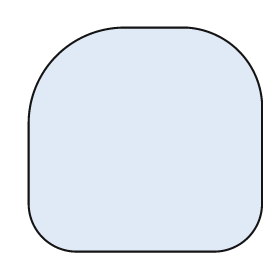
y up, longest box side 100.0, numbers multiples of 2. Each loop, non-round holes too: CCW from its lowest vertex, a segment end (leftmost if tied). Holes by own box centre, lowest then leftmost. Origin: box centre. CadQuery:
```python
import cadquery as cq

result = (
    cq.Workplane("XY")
    .moveTo(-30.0, -48.0)
    .lineTo(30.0, -48.0)
    .threePointArc((44.0, -42.0), (50.0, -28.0))
    .lineTo(50.0, 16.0)
    .threePointArc((40.0, 38.0), (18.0, 48.0))
    .lineTo(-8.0, 48.0)
    .threePointArc((-38.0, 36.0), (-50.0, 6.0))
    .lineTo(-50.0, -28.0)
    .threePointArc((-44.0, -42.0), (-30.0, -48.0))
    .close()
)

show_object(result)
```